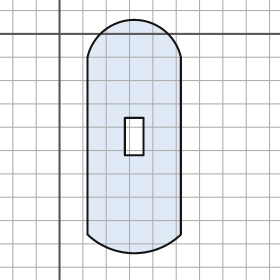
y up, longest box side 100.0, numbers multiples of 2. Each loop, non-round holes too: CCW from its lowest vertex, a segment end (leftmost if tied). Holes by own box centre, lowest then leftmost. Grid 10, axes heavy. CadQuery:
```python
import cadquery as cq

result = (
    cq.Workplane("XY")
    .moveTo(12.0, -86.0)
    .threePointArc((32.0, -94.0), (52.0, -86.0))
    .lineTo(52.0, -10.0)
    .threePointArc((32.0, 6.0), (12.0, -10.0))
    .close()
    .moveTo(28.0, -52.0)
    .lineTo(36.0, -52.0)
    .lineTo(36.0, -36.0)
    .lineTo(28.0, -36.0)
    .close()
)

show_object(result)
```